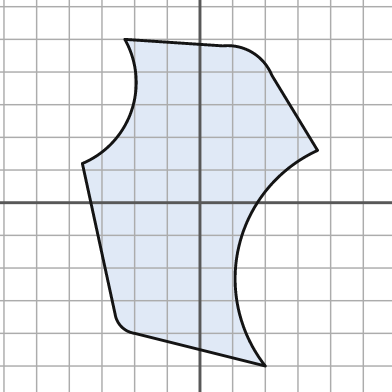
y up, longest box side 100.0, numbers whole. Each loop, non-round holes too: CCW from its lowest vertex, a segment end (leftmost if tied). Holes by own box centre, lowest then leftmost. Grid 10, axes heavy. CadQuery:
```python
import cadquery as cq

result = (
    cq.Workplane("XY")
    .moveTo(20.0, -50.0)
    .threePointArc((12.0, -13.0), (36.0, 16.0))
    .lineTo(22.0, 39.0)
    .threePointArc((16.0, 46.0), (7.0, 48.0))
    .lineTo(-23.0, 50.0)
    .threePointArc((-21.0, 28.0), (-36.0, 12.0))
    .lineTo(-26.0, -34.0)
    .threePointArc((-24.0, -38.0), (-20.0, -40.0))
    .close()
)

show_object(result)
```